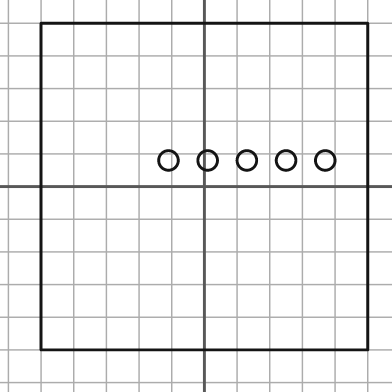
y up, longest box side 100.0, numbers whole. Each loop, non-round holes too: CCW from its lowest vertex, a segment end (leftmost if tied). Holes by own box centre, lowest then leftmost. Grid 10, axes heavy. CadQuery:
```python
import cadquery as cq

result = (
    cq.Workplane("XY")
    .moveTo(-50.0, -50.0)
    .lineTo(50.0, -50.0)
    .lineTo(50.0, 50.0)
    .lineTo(-50.0, 50.0)
    .close()
    .moveTo(-11.0, 8.0)
    .circle(3.0)
    .moveTo(1.0, 8.0)
    .circle(3.0)
    .moveTo(13.0, 8.0)
    .circle(3.0)
    .moveTo(25.0, 8.0)
    .circle(3.0)
    .moveTo(37.0, 8.0)
    .circle(3.0)
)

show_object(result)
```